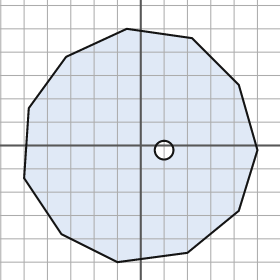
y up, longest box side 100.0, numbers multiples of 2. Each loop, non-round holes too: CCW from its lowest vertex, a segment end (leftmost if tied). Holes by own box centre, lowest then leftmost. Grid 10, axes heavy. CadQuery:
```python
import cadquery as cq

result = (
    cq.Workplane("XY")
    .moveTo(-10.0, -50.0)
    .lineTo(20.0, -46.0)
    .lineTo(42.0, -28.0)
    .lineTo(50.0, -2.0)
    .lineTo(42.0, 26.0)
    .lineTo(22.0, 46.0)
    .lineTo(-6.0, 50.0)
    .lineTo(-32.0, 38.0)
    .lineTo(-48.0, 16.0)
    .lineTo(-50.0, -14.0)
    .lineTo(-34.0, -38.0)
    .close()
    .moveTo(10.0, -2.0)
    .circle(4.0)
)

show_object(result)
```